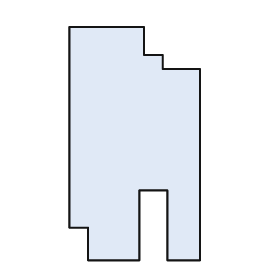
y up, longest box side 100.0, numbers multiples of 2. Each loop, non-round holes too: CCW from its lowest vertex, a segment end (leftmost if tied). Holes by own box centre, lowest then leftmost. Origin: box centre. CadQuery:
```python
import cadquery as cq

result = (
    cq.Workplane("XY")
    .moveTo(-20.0, -50.0)
    .lineTo(2.0, -50.0)
    .lineTo(2.0, -20.0)
    .lineTo(14.0, -20.0)
    .lineTo(14.0, -50.0)
    .lineTo(28.0, -50.0)
    .lineTo(28.0, 32.0)
    .lineTo(12.0, 32.0)
    .lineTo(12.0, 38.0)
    .lineTo(4.0, 38.0)
    .lineTo(4.0, 50.0)
    .lineTo(-28.0, 50.0)
    .lineTo(-28.0, -36.0)
    .lineTo(-20.0, -36.0)
    .close()
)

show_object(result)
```